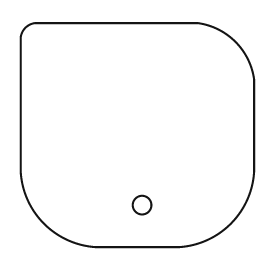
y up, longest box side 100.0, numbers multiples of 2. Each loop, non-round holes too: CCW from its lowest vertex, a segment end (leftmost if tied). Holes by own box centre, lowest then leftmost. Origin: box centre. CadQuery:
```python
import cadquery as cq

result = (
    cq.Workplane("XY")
    .moveTo(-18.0, -48.0)
    .lineTo(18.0, -48.0)
    .threePointArc((40.0, -38.0), (50.0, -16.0))
    .lineTo(50.0, 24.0)
    .threePointArc((42.0, 40.0), (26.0, 48.0))
    .lineTo(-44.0, 48.0)
    .threePointArc((-48.0, 46.0), (-50.0, 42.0))
    .lineTo(-50.0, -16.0)
    .threePointArc((-40.0, -38.0), (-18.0, -48.0))
    .close()
    .moveTo(2.0, -30.0)
    .circle(4.0)
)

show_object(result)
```